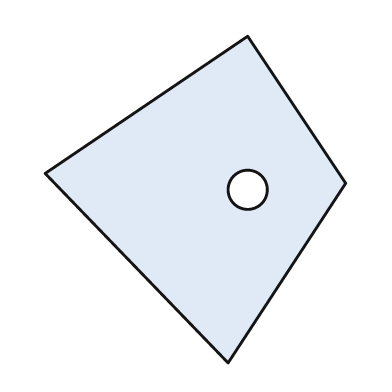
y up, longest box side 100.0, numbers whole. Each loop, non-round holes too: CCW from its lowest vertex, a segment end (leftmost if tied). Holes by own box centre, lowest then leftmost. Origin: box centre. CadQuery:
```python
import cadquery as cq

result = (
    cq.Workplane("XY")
    .moveTo(10.0, -50.0)
    .lineTo(46.0, 5.0)
    .lineTo(16.0, 50.0)
    .lineTo(-46.0, 8.0)
    .close()
    .moveTo(16.0, 3.0)
    .circle(6.0)
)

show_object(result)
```